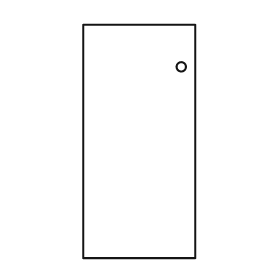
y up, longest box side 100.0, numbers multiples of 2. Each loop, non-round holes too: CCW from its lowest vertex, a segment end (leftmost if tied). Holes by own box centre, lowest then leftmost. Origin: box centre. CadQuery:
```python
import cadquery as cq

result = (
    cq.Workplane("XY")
    .moveTo(-24.0, -50.0)
    .lineTo(24.0, -50.0)
    .lineTo(24.0, 50.0)
    .lineTo(-24.0, 50.0)
    .close()
    .moveTo(18.0, 32.0)
    .circle(2.0)
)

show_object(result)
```